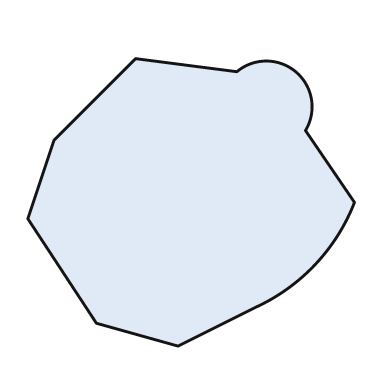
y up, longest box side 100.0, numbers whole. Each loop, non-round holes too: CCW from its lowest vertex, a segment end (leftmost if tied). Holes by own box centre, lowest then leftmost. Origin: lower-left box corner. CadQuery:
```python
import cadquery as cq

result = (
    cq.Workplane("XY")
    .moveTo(46.0, 0.0)
    .lineTo(70.0, 12.0)
    .threePointArc((88.0, 25.0), (100.0, 44.0))
    .lineTo(85.0, 66.0)
    .threePointArc((82.0, 84.0), (64.0, 84.0))
    .lineTo(33.0, 88.0)
    .lineTo(8.0, 63.0)
    .lineTo(0.0, 39.0)
    .lineTo(21.0, 7.0)
    .close()
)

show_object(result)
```